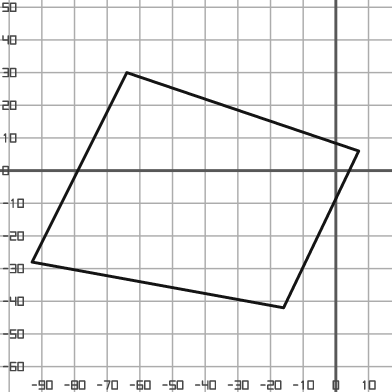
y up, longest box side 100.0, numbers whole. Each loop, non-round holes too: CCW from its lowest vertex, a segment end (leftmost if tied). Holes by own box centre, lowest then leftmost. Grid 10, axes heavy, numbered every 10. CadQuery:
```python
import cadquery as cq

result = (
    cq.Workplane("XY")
    .moveTo(-16.0, -42.0)
    .lineTo(7.0, 6.0)
    .lineTo(-64.0, 30.0)
    .lineTo(-93.0, -28.0)
    .close()
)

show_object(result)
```